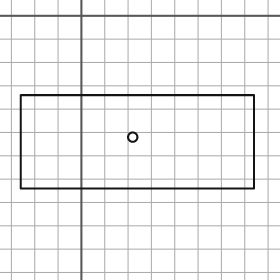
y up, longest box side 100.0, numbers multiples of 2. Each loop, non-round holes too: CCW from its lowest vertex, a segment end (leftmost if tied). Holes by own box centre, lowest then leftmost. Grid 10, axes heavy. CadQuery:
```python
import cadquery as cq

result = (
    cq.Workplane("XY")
    .moveTo(-26.0, -74.0)
    .lineTo(74.0, -74.0)
    .lineTo(74.0, -34.0)
    .lineTo(-26.0, -34.0)
    .close()
    .moveTo(22.0, -52.0)
    .circle(2.0)
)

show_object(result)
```